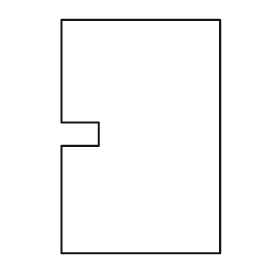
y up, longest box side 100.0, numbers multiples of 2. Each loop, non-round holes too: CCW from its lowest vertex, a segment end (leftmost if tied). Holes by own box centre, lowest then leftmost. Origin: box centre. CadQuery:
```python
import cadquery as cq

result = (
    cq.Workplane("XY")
    .moveTo(-34.0, -50.0)
    .lineTo(34.0, -50.0)
    .lineTo(34.0, 50.0)
    .lineTo(-34.0, 50.0)
    .lineTo(-34.0, 6.0)
    .lineTo(-18.0, 6.0)
    .lineTo(-18.0, -4.0)
    .lineTo(-34.0, -4.0)
    .close()
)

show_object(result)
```